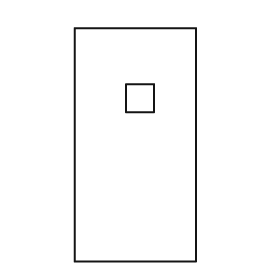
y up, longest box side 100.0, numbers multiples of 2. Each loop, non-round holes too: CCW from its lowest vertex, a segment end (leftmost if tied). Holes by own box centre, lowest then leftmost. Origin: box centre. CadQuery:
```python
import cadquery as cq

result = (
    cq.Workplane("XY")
    .moveTo(-26.0, -50.0)
    .lineTo(26.0, -50.0)
    .lineTo(26.0, 50.0)
    .lineTo(-26.0, 50.0)
    .close()
    .moveTo(-4.0, 14.0)
    .lineTo(8.0, 14.0)
    .lineTo(8.0, 26.0)
    .lineTo(-4.0, 26.0)
    .close()
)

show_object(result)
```